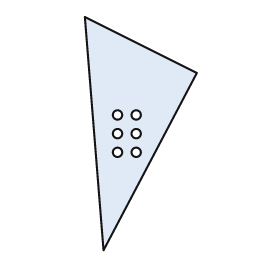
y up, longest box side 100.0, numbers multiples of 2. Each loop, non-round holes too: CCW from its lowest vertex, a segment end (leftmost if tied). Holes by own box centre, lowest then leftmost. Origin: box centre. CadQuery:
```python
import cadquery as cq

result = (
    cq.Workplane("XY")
    .moveTo(-16.0, -50.0)
    .lineTo(24.0, 26.0)
    .lineTo(-24.0, 50.0)
    .close()
    .moveTo(-10.0, -8.0)
    .circle(2.0)
    .moveTo(-2.0, -8.0)
    .circle(2.0)
    .moveTo(-10.0, 0.0)
    .circle(2.0)
    .moveTo(-2.0, 0.0)
    .circle(2.0)
    .moveTo(-10.0, 8.0)
    .circle(2.0)
    .moveTo(-2.0, 8.0)
    .circle(2.0)
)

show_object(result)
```